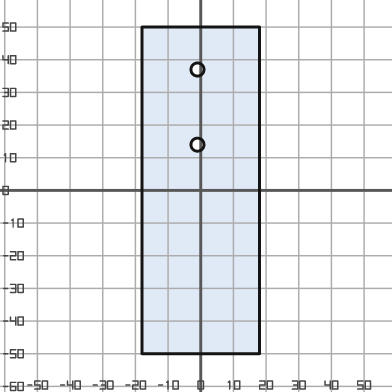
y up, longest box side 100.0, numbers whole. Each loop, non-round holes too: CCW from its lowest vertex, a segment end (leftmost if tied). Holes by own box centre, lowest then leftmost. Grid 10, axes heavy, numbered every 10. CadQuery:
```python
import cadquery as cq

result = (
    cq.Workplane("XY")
    .moveTo(-18.0, -50.0)
    .lineTo(18.0, -50.0)
    .lineTo(18.0, 50.0)
    .lineTo(-18.0, 50.0)
    .close()
    .moveTo(-1.0, 14.0)
    .circle(2.0)
    .moveTo(-1.0, 37.0)
    .circle(2.0)
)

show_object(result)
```